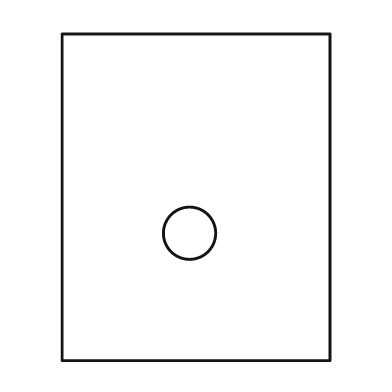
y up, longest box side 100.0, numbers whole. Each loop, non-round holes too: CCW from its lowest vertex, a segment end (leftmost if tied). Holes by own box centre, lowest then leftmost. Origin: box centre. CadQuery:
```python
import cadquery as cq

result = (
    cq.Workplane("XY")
    .moveTo(-41.0, -50.0)
    .lineTo(41.0, -50.0)
    .lineTo(41.0, 50.0)
    .lineTo(-41.0, 50.0)
    .close()
    .moveTo(-2.0, -11.0)
    .circle(8.0)
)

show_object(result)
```